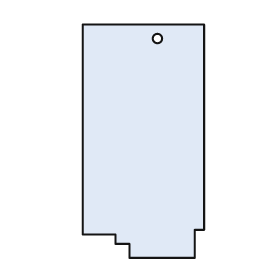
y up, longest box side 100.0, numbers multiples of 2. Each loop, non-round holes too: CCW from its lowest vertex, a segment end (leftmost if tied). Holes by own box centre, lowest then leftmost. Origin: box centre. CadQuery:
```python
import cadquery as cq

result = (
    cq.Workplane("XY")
    .moveTo(-6.0, -50.0)
    .lineTo(22.0, -50.0)
    .lineTo(22.0, -38.0)
    .lineTo(26.0, -38.0)
    .lineTo(26.0, 50.0)
    .lineTo(-26.0, 50.0)
    .lineTo(-26.0, -40.0)
    .lineTo(-12.0, -40.0)
    .lineTo(-12.0, -44.0)
    .lineTo(-6.0, -44.0)
    .close()
    .moveTo(6.0, 44.0)
    .circle(2.0)
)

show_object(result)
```